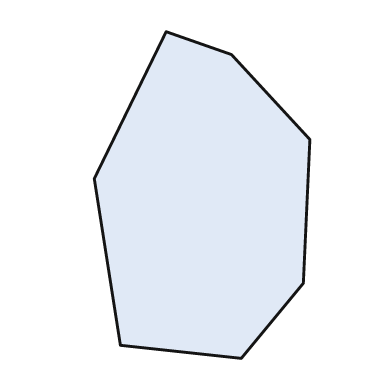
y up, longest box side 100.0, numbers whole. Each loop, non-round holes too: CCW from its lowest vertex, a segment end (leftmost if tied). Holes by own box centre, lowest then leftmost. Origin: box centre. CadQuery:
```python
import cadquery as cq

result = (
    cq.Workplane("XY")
    .moveTo(12.0, -50.0)
    .lineTo(31.0, -27.0)
    .lineTo(33.0, 17.0)
    .lineTo(9.0, 43.0)
    .lineTo(-11.0, 50.0)
    .lineTo(-33.0, 5.0)
    .lineTo(-25.0, -46.0)
    .close()
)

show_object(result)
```